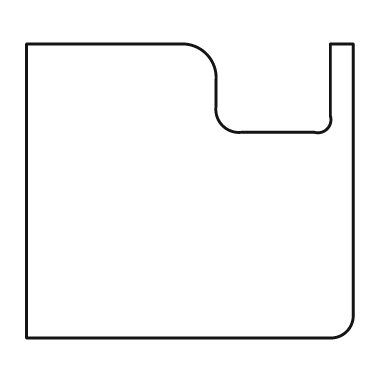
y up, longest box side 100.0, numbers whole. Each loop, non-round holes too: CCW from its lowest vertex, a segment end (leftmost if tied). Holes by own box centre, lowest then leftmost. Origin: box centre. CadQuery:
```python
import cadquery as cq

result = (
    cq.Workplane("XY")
    .moveTo(-50.0, -45.0)
    .lineTo(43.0, -45.0)
    .threePointArc((48.0, -43.0), (50.0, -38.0))
    .lineTo(50.0, 45.0)
    .lineTo(43.0, 45.0)
    .lineTo(43.0, 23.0)
    .threePointArc((42.0, 19.0), (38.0, 18.0))
    .lineTo(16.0, 18.0)
    .threePointArc((10.0, 20.0), (8.0, 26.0))
    .lineTo(8.0, 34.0)
    .threePointArc((5.0, 42.0), (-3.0, 45.0))
    .lineTo(-50.0, 45.0)
    .close()
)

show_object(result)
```